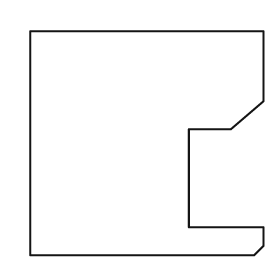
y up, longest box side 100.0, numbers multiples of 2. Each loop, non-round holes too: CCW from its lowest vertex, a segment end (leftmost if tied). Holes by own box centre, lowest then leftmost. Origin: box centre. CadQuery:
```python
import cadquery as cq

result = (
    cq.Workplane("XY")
    .moveTo(-50.0, -48.0)
    .lineTo(46.0, -48.0)
    .lineTo(50.0, -44.0)
    .lineTo(50.0, -36.0)
    .lineTo(18.0, -36.0)
    .lineTo(18.0, 6.0)
    .lineTo(36.0, 6.0)
    .lineTo(50.0, 18.0)
    .lineTo(50.0, 48.0)
    .lineTo(-50.0, 48.0)
    .close()
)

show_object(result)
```